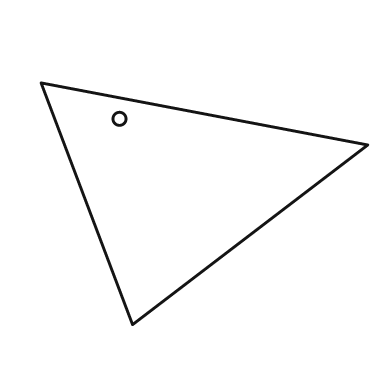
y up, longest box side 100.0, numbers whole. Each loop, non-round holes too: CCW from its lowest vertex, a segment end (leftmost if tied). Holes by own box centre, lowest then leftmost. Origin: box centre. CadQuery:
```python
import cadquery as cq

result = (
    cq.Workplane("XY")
    .moveTo(-22.0, -37.0)
    .lineTo(50.0, 18.0)
    .lineTo(-50.0, 37.0)
    .close()
    .moveTo(-26.0, 26.0)
    .circle(2.0)
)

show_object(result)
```